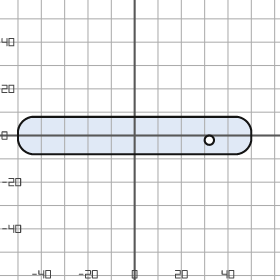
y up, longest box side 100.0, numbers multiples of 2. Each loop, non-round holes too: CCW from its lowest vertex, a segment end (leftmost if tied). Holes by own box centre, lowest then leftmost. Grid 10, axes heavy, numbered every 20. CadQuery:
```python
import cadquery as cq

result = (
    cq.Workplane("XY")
    .moveTo(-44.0, -8.0)
    .lineTo(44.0, -8.0)
    .threePointArc((48.0, -6.0), (50.0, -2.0))
    .lineTo(50.0, 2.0)
    .threePointArc((48.0, 6.0), (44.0, 8.0))
    .lineTo(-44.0, 8.0)
    .threePointArc((-48.0, 6.0), (-50.0, 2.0))
    .lineTo(-50.0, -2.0)
    .threePointArc((-48.0, -6.0), (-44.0, -8.0))
    .close()
    .moveTo(32.0, -2.0)
    .circle(2.0)
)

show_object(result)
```